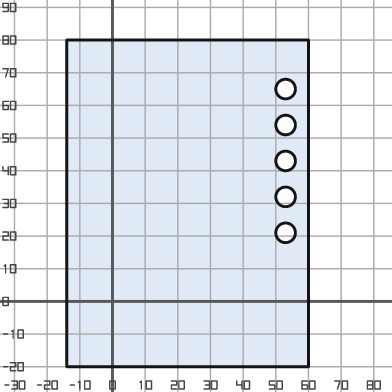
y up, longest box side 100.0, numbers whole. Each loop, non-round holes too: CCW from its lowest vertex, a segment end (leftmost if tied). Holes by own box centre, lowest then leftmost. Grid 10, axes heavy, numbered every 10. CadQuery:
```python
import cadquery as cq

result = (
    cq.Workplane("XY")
    .moveTo(-14.0, -20.0)
    .lineTo(60.0, -20.0)
    .lineTo(60.0, 80.0)
    .lineTo(-14.0, 80.0)
    .close()
    .moveTo(53.0, 21.0)
    .circle(3.0)
    .moveTo(53.0, 32.0)
    .circle(3.0)
    .moveTo(53.0, 43.0)
    .circle(3.0)
    .moveTo(53.0, 54.0)
    .circle(3.0)
    .moveTo(53.0, 65.0)
    .circle(3.0)
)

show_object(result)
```